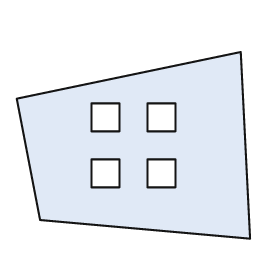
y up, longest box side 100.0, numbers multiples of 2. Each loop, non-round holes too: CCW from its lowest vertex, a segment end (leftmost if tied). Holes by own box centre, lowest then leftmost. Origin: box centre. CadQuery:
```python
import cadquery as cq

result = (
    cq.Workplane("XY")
    .moveTo(50.0, -40.0)
    .lineTo(46.0, 40.0)
    .lineTo(-50.0, 20.0)
    .lineTo(-40.0, -32.0)
    .close()
    .moveTo(-18.0, -18.0)
    .lineTo(-6.0, -18.0)
    .lineTo(-6.0, -6.0)
    .lineTo(-18.0, -6.0)
    .close()
    .moveTo(6.0, -18.0)
    .lineTo(18.0, -18.0)
    .lineTo(18.0, -6.0)
    .lineTo(6.0, -6.0)
    .close()
    .moveTo(-18.0, 6.0)
    .lineTo(-6.0, 6.0)
    .lineTo(-6.0, 18.0)
    .lineTo(-18.0, 18.0)
    .close()
    .moveTo(6.0, 6.0)
    .lineTo(18.0, 6.0)
    .lineTo(18.0, 18.0)
    .lineTo(6.0, 18.0)
    .close()
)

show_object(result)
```